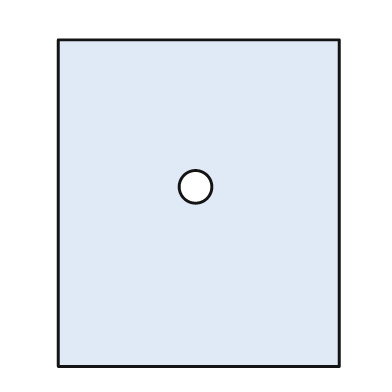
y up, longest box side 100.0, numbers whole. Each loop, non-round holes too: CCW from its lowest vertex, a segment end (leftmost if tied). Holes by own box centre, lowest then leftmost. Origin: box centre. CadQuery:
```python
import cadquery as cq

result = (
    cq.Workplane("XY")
    .moveTo(-43.0, -50.0)
    .lineTo(43.0, -50.0)
    .lineTo(43.0, 50.0)
    .lineTo(-43.0, 50.0)
    .close()
    .moveTo(-1.0, 5.0)
    .circle(5.0)
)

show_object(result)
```